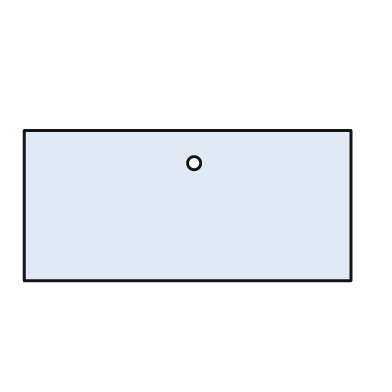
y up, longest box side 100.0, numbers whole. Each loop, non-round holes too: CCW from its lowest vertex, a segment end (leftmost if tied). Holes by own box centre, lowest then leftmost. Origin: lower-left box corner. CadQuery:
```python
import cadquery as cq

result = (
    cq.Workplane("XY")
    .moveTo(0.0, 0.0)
    .lineTo(100.0, 0.0)
    .lineTo(100.0, 46.0)
    .lineTo(0.0, 46.0)
    .close()
    .moveTo(52.0, 36.0)
    .circle(2.0)
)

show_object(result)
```